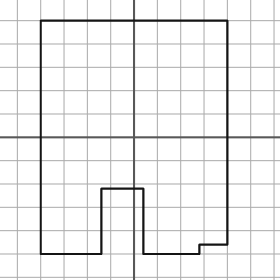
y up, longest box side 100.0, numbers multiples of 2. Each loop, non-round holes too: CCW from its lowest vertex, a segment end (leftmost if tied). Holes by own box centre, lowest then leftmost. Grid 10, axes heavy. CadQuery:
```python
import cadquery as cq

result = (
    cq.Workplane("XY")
    .moveTo(-40.0, -50.0)
    .lineTo(-14.0, -50.0)
    .lineTo(-14.0, -22.0)
    .lineTo(4.0, -22.0)
    .lineTo(4.0, -50.0)
    .lineTo(28.0, -50.0)
    .lineTo(28.0, -46.0)
    .lineTo(40.0, -46.0)
    .lineTo(40.0, 50.0)
    .lineTo(-40.0, 50.0)
    .close()
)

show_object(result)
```